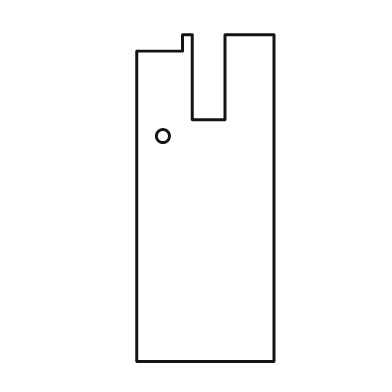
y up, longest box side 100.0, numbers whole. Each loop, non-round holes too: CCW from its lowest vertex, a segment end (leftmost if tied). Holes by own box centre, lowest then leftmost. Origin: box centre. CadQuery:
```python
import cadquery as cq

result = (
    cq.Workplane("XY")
    .moveTo(-21.0, -50.0)
    .lineTo(21.0, -50.0)
    .lineTo(21.0, 50.0)
    .lineTo(6.0, 50.0)
    .lineTo(6.0, 24.0)
    .lineTo(-4.0, 24.0)
    .lineTo(-4.0, 50.0)
    .lineTo(-7.0, 50.0)
    .lineTo(-7.0, 45.0)
    .lineTo(-21.0, 45.0)
    .close()
    .moveTo(-13.0, 19.0)
    .circle(2.0)
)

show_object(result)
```